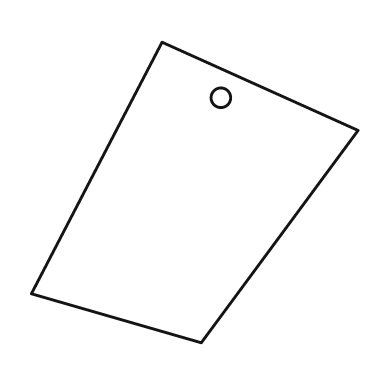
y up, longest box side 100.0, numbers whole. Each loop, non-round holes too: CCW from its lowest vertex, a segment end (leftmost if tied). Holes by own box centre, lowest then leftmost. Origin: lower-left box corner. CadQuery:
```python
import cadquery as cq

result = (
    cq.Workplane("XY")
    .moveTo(52.0, 0.0)
    .lineTo(100.0, 65.0)
    .lineTo(40.0, 92.0)
    .lineTo(0.0, 15.0)
    .close()
    .moveTo(58.0, 75.0)
    .circle(3.0)
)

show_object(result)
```